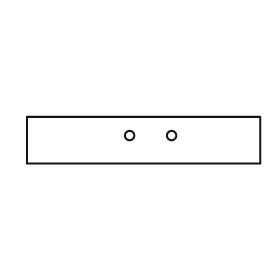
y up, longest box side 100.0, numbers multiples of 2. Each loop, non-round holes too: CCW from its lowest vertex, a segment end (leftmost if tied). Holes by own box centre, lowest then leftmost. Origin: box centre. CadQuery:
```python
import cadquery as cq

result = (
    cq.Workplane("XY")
    .moveTo(-50.0, -10.0)
    .lineTo(50.0, -10.0)
    .lineTo(50.0, 10.0)
    .lineTo(-50.0, 10.0)
    .close()
    .moveTo(-6.0, 2.0)
    .circle(2.0)
    .moveTo(12.0, 2.0)
    .circle(2.0)
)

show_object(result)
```